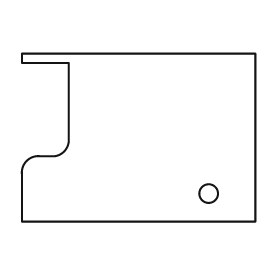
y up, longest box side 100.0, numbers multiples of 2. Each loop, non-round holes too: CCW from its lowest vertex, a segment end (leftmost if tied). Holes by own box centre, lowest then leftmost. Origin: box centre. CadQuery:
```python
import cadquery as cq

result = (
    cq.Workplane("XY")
    .moveTo(-50.0, -36.0)
    .lineTo(50.0, -36.0)
    .lineTo(50.0, 36.0)
    .lineTo(-50.0, 36.0)
    .lineTo(-50.0, 32.0)
    .lineTo(-30.0, 32.0)
    .lineTo(-30.0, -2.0)
    .threePointArc((-32.0, -6.0), (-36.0, -8.0))
    .lineTo(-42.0, -8.0)
    .threePointArc((-48.0, -10.0), (-50.0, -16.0))
    .close()
    .moveTo(30.0, -24.0)
    .circle(4.0)
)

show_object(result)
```